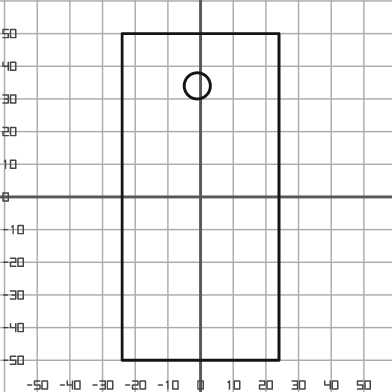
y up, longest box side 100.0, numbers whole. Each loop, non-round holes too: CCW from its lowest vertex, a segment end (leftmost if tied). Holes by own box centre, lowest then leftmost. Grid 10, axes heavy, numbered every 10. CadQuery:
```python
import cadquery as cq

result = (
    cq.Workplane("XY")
    .moveTo(-24.0, -50.0)
    .lineTo(24.0, -50.0)
    .lineTo(24.0, 50.0)
    .lineTo(-24.0, 50.0)
    .close()
    .moveTo(-1.0, 34.0)
    .circle(4.0)
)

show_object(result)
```